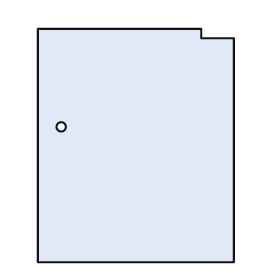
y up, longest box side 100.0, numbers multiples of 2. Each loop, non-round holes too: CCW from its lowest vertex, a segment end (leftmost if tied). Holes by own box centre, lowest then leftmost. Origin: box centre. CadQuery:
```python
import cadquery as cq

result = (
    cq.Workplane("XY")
    .moveTo(-42.0, -50.0)
    .lineTo(42.0, -50.0)
    .lineTo(42.0, 46.0)
    .lineTo(28.0, 46.0)
    .lineTo(28.0, 50.0)
    .lineTo(-42.0, 50.0)
    .close()
    .moveTo(-32.0, 8.0)
    .circle(2.0)
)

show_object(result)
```